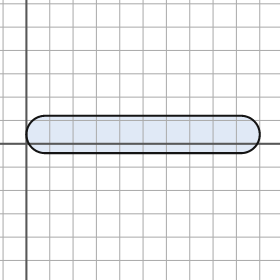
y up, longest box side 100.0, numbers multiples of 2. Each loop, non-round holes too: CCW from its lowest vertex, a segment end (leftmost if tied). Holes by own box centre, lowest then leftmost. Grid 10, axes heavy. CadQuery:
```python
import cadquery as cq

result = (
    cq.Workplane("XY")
    .moveTo(8.0, -4.0)
    .lineTo(92.0, -4.0)
    .threePointArc((100.0, 4.0), (92.0, 12.0))
    .lineTo(8.0, 12.0)
    .threePointArc((0.0, 4.0), (8.0, -4.0))
    .close()
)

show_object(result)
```